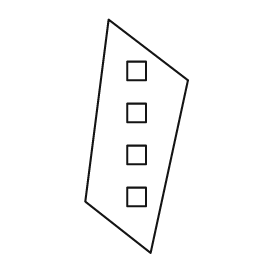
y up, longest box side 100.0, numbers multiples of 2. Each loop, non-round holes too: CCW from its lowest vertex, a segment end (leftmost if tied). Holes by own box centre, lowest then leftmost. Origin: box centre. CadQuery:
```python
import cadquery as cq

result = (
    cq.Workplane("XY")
    .moveTo(6.0, -50.0)
    .lineTo(22.0, 24.0)
    .lineTo(-12.0, 50.0)
    .lineTo(-22.0, -28.0)
    .close()
    .moveTo(-4.0, -30.0)
    .lineTo(4.0, -30.0)
    .lineTo(4.0, -22.0)
    .lineTo(-4.0, -22.0)
    .close()
    .moveTo(-4.0, -12.0)
    .lineTo(4.0, -12.0)
    .lineTo(4.0, -4.0)
    .lineTo(-4.0, -4.0)
    .close()
    .moveTo(-4.0, 6.0)
    .lineTo(4.0, 6.0)
    .lineTo(4.0, 14.0)
    .lineTo(-4.0, 14.0)
    .close()
    .moveTo(-4.0, 24.0)
    .lineTo(4.0, 24.0)
    .lineTo(4.0, 32.0)
    .lineTo(-4.0, 32.0)
    .close()
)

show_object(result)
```